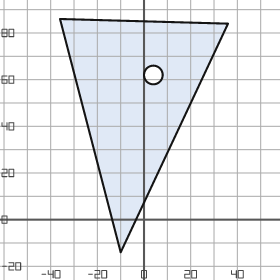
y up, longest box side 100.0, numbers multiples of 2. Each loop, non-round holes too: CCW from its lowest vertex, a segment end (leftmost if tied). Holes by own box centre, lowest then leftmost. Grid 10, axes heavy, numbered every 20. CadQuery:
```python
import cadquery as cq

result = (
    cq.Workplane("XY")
    .moveTo(-10.0, -14.0)
    .lineTo(36.0, 84.0)
    .lineTo(-36.0, 86.0)
    .close()
    .moveTo(4.0, 62.0)
    .circle(4.0)
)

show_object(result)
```